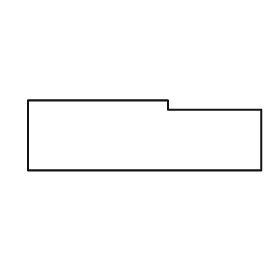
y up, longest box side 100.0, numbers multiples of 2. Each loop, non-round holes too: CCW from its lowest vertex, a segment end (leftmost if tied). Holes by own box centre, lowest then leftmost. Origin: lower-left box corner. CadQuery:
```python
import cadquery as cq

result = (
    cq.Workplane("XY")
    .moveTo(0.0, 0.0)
    .lineTo(100.0, 0.0)
    .lineTo(100.0, 26.0)
    .lineTo(60.0, 26.0)
    .lineTo(60.0, 30.0)
    .lineTo(0.0, 30.0)
    .close()
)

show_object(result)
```